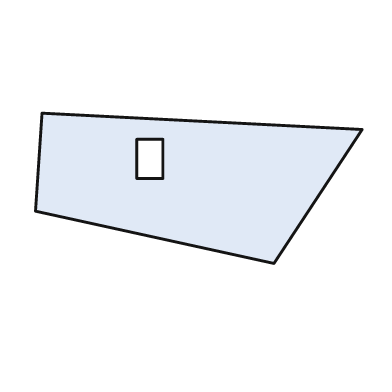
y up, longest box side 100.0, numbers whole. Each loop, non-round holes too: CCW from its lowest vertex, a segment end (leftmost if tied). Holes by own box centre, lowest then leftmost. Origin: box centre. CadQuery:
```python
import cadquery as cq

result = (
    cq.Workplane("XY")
    .moveTo(23.0, -23.0)
    .lineTo(50.0, 18.0)
    .lineTo(-48.0, 23.0)
    .lineTo(-50.0, -7.0)
    .close()
    .moveTo(-19.0, 3.0)
    .lineTo(-11.0, 3.0)
    .lineTo(-11.0, 15.0)
    .lineTo(-19.0, 15.0)
    .close()
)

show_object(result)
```